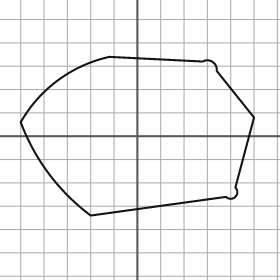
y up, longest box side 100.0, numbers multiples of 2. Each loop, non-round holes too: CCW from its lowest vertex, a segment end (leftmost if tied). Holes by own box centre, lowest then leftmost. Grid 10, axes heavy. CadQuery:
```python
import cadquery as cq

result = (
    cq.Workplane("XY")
    .moveTo(-20.0, -34.0)
    .lineTo(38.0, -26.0)
    .threePointArc((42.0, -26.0), (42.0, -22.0))
    .lineTo(50.0, 8.0)
    .lineTo(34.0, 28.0)
    .threePointArc((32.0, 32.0), (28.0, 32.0))
    .lineTo(-12.0, 34.0)
    .threePointArc((-34.0, 24.0), (-50.0, 6.0))
    .threePointArc((-38.0, -16.0), (-20.0, -34.0))
    .close()
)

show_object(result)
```